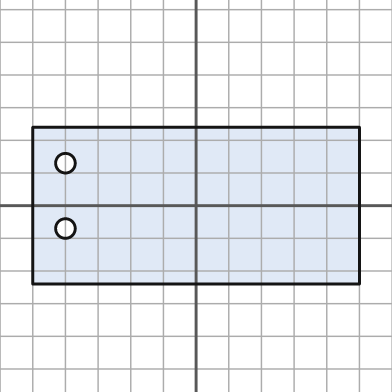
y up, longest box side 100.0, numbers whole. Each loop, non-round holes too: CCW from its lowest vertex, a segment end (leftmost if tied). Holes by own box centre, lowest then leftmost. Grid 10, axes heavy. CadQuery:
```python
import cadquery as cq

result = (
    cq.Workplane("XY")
    .moveTo(-50.0, -24.0)
    .lineTo(50.0, -24.0)
    .lineTo(50.0, 24.0)
    .lineTo(-50.0, 24.0)
    .close()
    .moveTo(-40.0, -7.0)
    .circle(3.0)
    .moveTo(-40.0, 13.0)
    .circle(3.0)
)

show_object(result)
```